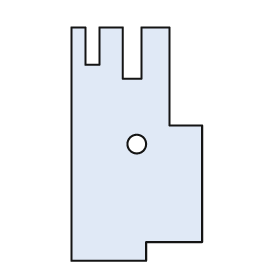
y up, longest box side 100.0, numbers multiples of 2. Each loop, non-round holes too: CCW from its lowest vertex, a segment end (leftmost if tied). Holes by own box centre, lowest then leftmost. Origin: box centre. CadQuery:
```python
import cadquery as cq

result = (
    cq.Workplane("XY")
    .moveTo(-28.0, -50.0)
    .lineTo(4.0, -50.0)
    .lineTo(4.0, -42.0)
    .lineTo(28.0, -42.0)
    .lineTo(28.0, 8.0)
    .lineTo(14.0, 8.0)
    .lineTo(14.0, 50.0)
    .lineTo(2.0, 50.0)
    .lineTo(2.0, 28.0)
    .lineTo(-6.0, 28.0)
    .lineTo(-6.0, 50.0)
    .lineTo(-16.0, 50.0)
    .lineTo(-16.0, 34.0)
    .lineTo(-22.0, 34.0)
    .lineTo(-22.0, 50.0)
    .lineTo(-28.0, 50.0)
    .close()
    .moveTo(0.0, 0.0)
    .circle(4.0)
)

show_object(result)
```